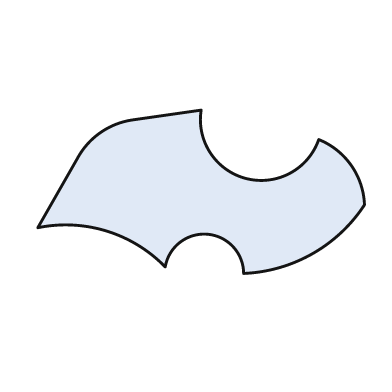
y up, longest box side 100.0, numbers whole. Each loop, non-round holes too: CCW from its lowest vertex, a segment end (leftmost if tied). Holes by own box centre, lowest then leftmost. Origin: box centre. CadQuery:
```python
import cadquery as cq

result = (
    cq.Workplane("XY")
    .moveTo(13.0, -25.0)
    .threePointArc((34.0, -19.0), (50.0, -4.0))
    .threePointArc((46.0, 8.0), (36.0, 16.0))
    .threePointArc((14.0, 4.0), (0.0, 25.0))
    .lineTo(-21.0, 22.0)
    .threePointArc((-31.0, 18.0), (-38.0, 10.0))
    .lineTo(-50.0, -11.0)
    .threePointArc((-29.0, -12.0), (-11.0, -23.0))
    .threePointArc((2.0, -13.0), (13.0, -25.0))
    .close()
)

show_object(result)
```